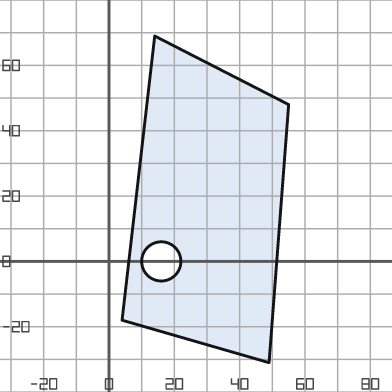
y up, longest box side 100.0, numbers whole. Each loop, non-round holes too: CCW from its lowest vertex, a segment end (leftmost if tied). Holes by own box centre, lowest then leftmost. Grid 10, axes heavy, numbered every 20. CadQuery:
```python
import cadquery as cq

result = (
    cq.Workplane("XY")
    .moveTo(49.0, -31.0)
    .lineTo(55.0, 48.0)
    .lineTo(14.0, 69.0)
    .lineTo(4.0, -18.0)
    .close()
    .moveTo(16.0, 0.0)
    .circle(6.0)
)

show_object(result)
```